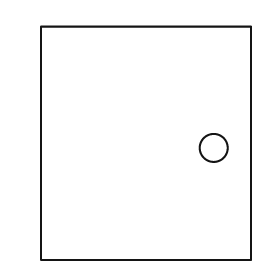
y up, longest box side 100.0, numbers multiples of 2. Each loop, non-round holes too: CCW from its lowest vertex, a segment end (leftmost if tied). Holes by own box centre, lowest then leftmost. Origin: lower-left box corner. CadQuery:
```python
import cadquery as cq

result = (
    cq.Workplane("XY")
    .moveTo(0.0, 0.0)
    .lineTo(90.0, 0.0)
    .lineTo(90.0, 100.0)
    .lineTo(0.0, 100.0)
    .close()
    .moveTo(74.0, 48.0)
    .circle(6.0)
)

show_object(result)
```